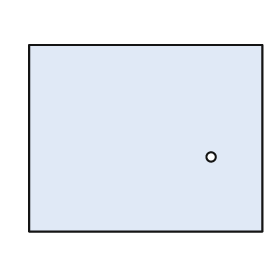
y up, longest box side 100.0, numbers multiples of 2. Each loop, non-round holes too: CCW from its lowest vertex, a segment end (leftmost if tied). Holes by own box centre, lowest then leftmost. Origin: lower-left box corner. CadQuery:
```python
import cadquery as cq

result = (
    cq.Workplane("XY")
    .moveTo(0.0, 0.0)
    .lineTo(100.0, 0.0)
    .lineTo(100.0, 80.0)
    .lineTo(0.0, 80.0)
    .close()
    .moveTo(78.0, 32.0)
    .circle(2.0)
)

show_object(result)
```